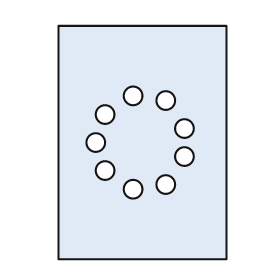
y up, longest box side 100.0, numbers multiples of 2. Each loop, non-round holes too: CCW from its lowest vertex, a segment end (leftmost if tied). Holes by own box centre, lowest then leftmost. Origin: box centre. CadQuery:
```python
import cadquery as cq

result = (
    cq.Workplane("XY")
    .moveTo(-36.0, -50.0)
    .lineTo(36.0, -50.0)
    .lineTo(36.0, 50.0)
    .lineTo(-36.0, 50.0)
    .close()
    .moveTo(-4.0, -20.0)
    .circle(4.0)
    .moveTo(10.0, -18.0)
    .circle(4.0)
    .moveTo(-16.0, -12.0)
    .circle(4.0)
    .moveTo(18.0, -6.0)
    .circle(4.0)
    .moveTo(-20.0, 0.0)
    .circle(4.0)
    .moveTo(18.0, 6.0)
    .circle(4.0)
    .moveTo(-16.0, 12.0)
    .circle(4.0)
    .moveTo(10.0, 18.0)
    .circle(4.0)
    .moveTo(-4.0, 20.0)
    .circle(4.0)
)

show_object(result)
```